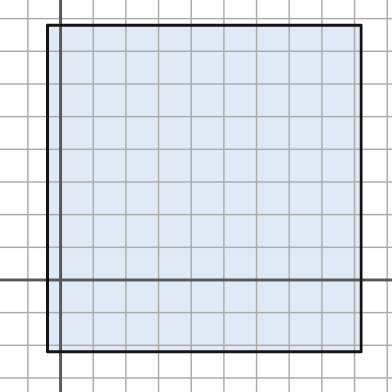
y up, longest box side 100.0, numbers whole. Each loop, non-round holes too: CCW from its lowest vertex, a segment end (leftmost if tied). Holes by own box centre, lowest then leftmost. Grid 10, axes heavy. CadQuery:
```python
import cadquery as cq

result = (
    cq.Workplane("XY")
    .moveTo(-4.0, -22.0)
    .lineTo(92.0, -22.0)
    .lineTo(92.0, 78.0)
    .lineTo(-4.0, 78.0)
    .close()
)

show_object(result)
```